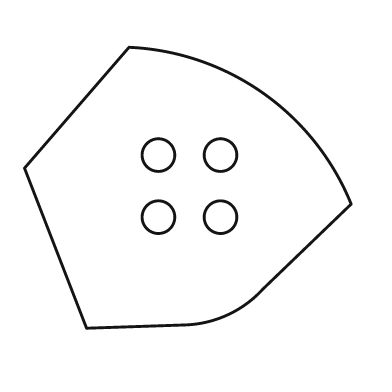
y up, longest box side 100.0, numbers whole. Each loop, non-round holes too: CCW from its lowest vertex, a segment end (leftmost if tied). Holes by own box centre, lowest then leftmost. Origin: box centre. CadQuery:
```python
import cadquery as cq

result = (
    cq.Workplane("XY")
    .moveTo(-31.0, -43.0)
    .lineTo(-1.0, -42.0)
    .threePointArc((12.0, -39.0), (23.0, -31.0))
    .lineTo(50.0, -5.0)
    .threePointArc((23.0, 29.0), (-18.0, 43.0))
    .lineTo(-50.0, 6.0)
    .close()
    .moveTo(-9.0, -9.0)
    .circle(5.0)
    .moveTo(10.0, -9.0)
    .circle(5.0)
    .moveTo(-9.0, 10.0)
    .circle(5.0)
    .moveTo(10.0, 10.0)
    .circle(5.0)
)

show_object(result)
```